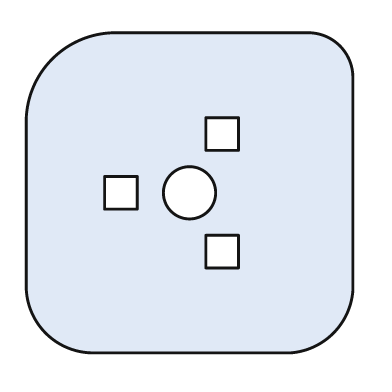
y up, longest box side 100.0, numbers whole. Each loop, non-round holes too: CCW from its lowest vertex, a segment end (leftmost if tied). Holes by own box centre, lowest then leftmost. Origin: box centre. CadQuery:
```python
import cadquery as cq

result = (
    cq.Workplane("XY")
    .moveTo(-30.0, -49.0)
    .lineTo(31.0, -49.0)
    .threePointArc((44.0, -43.0), (50.0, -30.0))
    .lineTo(50.0, 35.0)
    .threePointArc((46.0, 45.0), (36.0, 49.0))
    .lineTo(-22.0, 49.0)
    .threePointArc((-42.0, 41.0), (-50.0, 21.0))
    .lineTo(-50.0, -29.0)
    .threePointArc((-44.0, -43.0), (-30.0, -49.0))
    .close()
    .moveTo(5.0, -23.0)
    .lineTo(15.0, -23.0)
    .lineTo(15.0, -13.0)
    .lineTo(5.0, -13.0)
    .close()
    .moveTo(-26.0, -5.0)
    .lineTo(-16.0, -5.0)
    .lineTo(-16.0, 5.0)
    .lineTo(-26.0, 5.0)
    .close()
    .moveTo(0.0, 0.0)
    .circle(8.0)
    .moveTo(5.0, 13.0)
    .lineTo(15.0, 13.0)
    .lineTo(15.0, 23.0)
    .lineTo(5.0, 23.0)
    .close()
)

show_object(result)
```